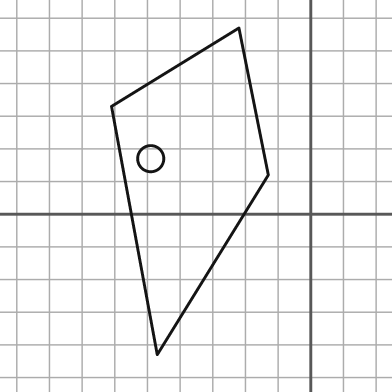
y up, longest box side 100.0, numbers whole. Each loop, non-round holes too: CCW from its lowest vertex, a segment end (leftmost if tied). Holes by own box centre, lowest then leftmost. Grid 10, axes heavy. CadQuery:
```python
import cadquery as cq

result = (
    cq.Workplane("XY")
    .moveTo(-47.0, -43.0)
    .lineTo(-13.0, 12.0)
    .lineTo(-22.0, 57.0)
    .lineTo(-61.0, 33.0)
    .close()
    .moveTo(-49.0, 17.0)
    .circle(4.0)
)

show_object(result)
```